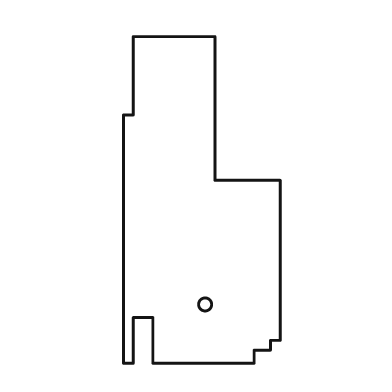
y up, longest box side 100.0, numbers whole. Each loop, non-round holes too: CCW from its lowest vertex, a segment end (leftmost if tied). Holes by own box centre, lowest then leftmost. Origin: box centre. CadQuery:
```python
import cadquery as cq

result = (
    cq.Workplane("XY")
    .moveTo(-24.0, -50.0)
    .lineTo(-21.0, -50.0)
    .lineTo(-21.0, -36.0)
    .lineTo(-15.0, -36.0)
    .lineTo(-15.0, -50.0)
    .lineTo(16.0, -50.0)
    .lineTo(16.0, -46.0)
    .lineTo(21.0, -46.0)
    .lineTo(21.0, -43.0)
    .lineTo(24.0, -43.0)
    .lineTo(24.0, 6.0)
    .lineTo(4.0, 6.0)
    .lineTo(4.0, 50.0)
    .lineTo(-21.0, 50.0)
    .lineTo(-21.0, 26.0)
    .lineTo(-24.0, 26.0)
    .close()
    .moveTo(1.0, -32.0)
    .circle(2.0)
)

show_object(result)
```